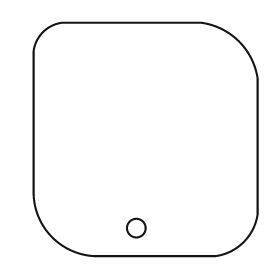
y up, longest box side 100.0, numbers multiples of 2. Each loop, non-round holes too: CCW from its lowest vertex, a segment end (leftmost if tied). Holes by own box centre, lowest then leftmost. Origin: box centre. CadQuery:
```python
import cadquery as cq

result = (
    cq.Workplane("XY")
    .moveTo(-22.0, -50.0)
    .lineTo(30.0, -50.0)
    .threePointArc((42.0, -44.0), (48.0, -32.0))
    .lineTo(48.0, 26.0)
    .threePointArc((40.0, 42.0), (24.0, 50.0))
    .lineTo(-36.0, 50.0)
    .threePointArc((-44.0, 46.0), (-48.0, 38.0))
    .lineTo(-48.0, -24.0)
    .threePointArc((-40.0, -42.0), (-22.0, -50.0))
    .close()
    .moveTo(-4.0, -38.0)
    .circle(4.0)
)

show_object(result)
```